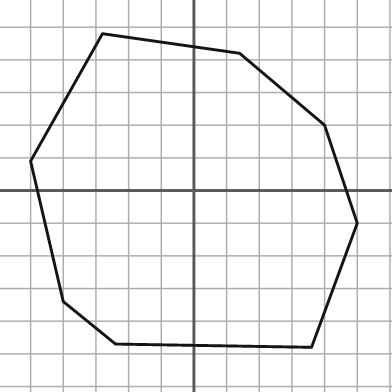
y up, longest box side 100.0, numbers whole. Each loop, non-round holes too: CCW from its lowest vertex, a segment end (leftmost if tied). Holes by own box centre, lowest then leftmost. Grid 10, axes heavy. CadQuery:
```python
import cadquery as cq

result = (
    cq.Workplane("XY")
    .moveTo(36.0, -48.0)
    .lineTo(50.0, -10.0)
    .lineTo(40.0, 20.0)
    .lineTo(14.0, 42.0)
    .lineTo(-28.0, 48.0)
    .lineTo(-50.0, 9.0)
    .lineTo(-40.0, -34.0)
    .lineTo(-24.0, -47.0)
    .close()
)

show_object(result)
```